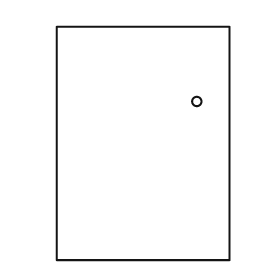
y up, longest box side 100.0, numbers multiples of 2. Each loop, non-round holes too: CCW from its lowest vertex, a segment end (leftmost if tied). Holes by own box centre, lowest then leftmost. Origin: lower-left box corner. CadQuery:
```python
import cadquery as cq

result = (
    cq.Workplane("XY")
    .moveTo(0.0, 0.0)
    .lineTo(74.0, 0.0)
    .lineTo(74.0, 100.0)
    .lineTo(0.0, 100.0)
    .close()
    .moveTo(60.0, 68.0)
    .circle(2.0)
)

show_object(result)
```